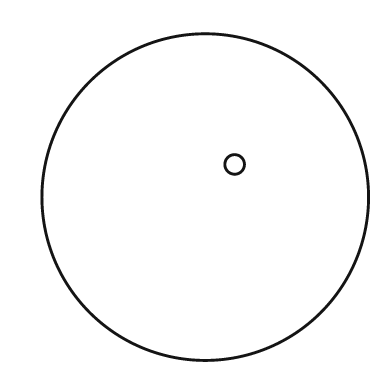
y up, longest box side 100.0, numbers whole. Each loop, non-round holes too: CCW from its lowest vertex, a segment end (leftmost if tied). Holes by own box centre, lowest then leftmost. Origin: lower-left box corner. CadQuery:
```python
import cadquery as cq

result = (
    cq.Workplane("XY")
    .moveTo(50.0, 50.0)
    .circle(50.0)
    .moveTo(59.0, 60.0)
    .circle(3.0)
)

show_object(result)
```